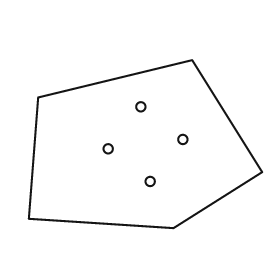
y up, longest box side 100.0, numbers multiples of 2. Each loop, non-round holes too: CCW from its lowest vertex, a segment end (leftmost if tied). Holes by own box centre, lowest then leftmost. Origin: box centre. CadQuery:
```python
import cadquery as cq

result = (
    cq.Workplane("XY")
    .moveTo(12.0, -36.0)
    .lineTo(50.0, -12.0)
    .lineTo(20.0, 36.0)
    .lineTo(-46.0, 20.0)
    .lineTo(-50.0, -32.0)
    .close()
    .moveTo(2.0, -16.0)
    .circle(2.0)
    .moveTo(-16.0, -2.0)
    .circle(2.0)
    .moveTo(16.0, 2.0)
    .circle(2.0)
    .moveTo(-2.0, 16.0)
    .circle(2.0)
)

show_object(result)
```